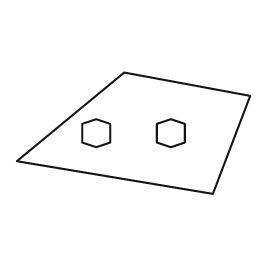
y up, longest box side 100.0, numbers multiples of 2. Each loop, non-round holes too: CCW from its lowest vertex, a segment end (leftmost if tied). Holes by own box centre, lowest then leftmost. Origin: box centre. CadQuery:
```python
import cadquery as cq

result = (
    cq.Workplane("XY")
    .moveTo(34.0, -26.0)
    .lineTo(50.0, 16.0)
    .lineTo(-4.0, 26.0)
    .lineTo(-50.0, -12.0)
    .close()
    .moveTo(-16.0, -6.0)
    .lineTo(-10.0, -4.0)
    .lineTo(-10.0, 4.0)
    .lineTo(-16.0, 6.0)
    .lineTo(-22.0, 4.0)
    .lineTo(-22.0, -4.0)
    .close()
    .moveTo(16.0, -6.0)
    .lineTo(22.0, -4.0)
    .lineTo(22.0, 4.0)
    .lineTo(16.0, 6.0)
    .lineTo(10.0, 4.0)
    .lineTo(10.0, -4.0)
    .close()
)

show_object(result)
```